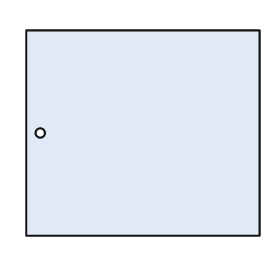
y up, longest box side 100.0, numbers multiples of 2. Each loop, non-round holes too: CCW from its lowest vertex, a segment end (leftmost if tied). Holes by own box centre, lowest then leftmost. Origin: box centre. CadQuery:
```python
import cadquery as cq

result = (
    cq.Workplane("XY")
    .moveTo(-50.0, -44.0)
    .lineTo(50.0, -44.0)
    .lineTo(50.0, 44.0)
    .lineTo(-50.0, 44.0)
    .close()
    .moveTo(-44.0, 0.0)
    .circle(2.0)
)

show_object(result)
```